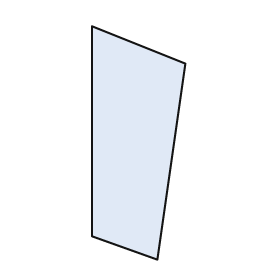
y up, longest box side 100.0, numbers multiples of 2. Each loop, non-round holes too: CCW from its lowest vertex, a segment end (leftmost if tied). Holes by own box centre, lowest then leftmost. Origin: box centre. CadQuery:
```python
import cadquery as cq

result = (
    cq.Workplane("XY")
    .moveTo(8.0, -50.0)
    .lineTo(20.0, 34.0)
    .lineTo(-20.0, 50.0)
    .lineTo(-20.0, -40.0)
    .close()
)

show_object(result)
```